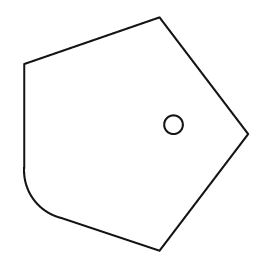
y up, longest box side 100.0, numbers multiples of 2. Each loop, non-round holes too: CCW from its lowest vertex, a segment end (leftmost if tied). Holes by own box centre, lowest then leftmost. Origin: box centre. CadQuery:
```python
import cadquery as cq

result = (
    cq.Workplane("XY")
    .moveTo(10.0, -50.0)
    .lineTo(48.0, 0.0)
    .lineTo(10.0, 50.0)
    .lineTo(-48.0, 30.0)
    .lineTo(-48.0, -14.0)
    .threePointArc((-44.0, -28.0), (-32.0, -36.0))
    .close()
    .moveTo(16.0, 4.0)
    .circle(4.0)
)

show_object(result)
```